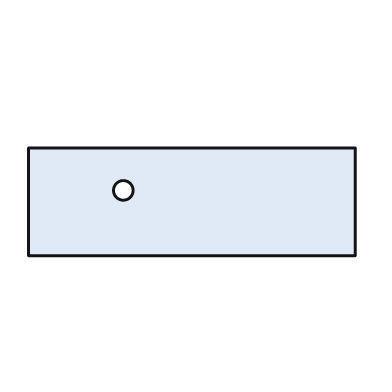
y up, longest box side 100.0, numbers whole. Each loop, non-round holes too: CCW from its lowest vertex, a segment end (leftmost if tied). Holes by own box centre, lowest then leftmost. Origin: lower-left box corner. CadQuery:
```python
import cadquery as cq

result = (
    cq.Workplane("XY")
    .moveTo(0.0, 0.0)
    .lineTo(100.0, 0.0)
    .lineTo(100.0, 33.0)
    .lineTo(0.0, 33.0)
    .close()
    .moveTo(29.0, 20.0)
    .circle(3.0)
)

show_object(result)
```